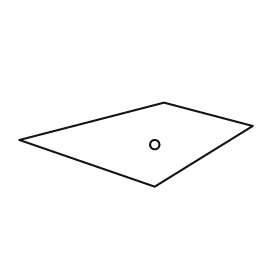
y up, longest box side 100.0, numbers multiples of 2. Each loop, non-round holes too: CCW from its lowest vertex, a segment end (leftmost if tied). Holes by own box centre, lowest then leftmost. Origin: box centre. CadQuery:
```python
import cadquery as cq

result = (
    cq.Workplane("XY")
    .moveTo(8.0, -18.0)
    .lineTo(50.0, 8.0)
    .lineTo(12.0, 18.0)
    .lineTo(-50.0, 2.0)
    .close()
    .moveTo(8.0, 0.0)
    .circle(2.0)
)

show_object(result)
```